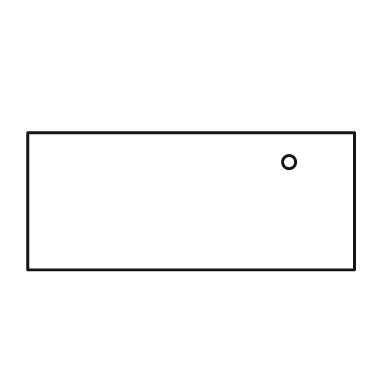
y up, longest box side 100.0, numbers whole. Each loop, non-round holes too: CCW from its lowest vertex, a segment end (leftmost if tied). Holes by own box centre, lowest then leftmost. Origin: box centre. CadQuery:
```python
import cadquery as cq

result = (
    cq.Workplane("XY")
    .moveTo(-50.0, -21.0)
    .lineTo(50.0, -21.0)
    .lineTo(50.0, 21.0)
    .lineTo(-50.0, 21.0)
    .close()
    .moveTo(30.0, 12.0)
    .circle(2.0)
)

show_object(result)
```